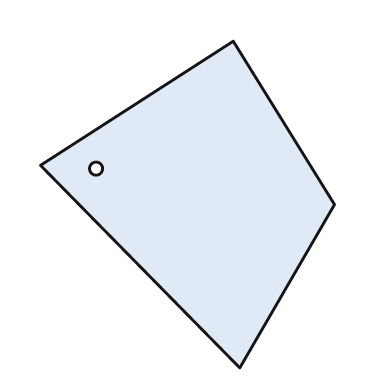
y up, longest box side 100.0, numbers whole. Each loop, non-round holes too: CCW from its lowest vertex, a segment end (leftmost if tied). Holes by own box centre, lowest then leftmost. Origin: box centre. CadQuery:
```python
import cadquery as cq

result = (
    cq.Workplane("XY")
    .moveTo(16.0, -50.0)
    .lineTo(45.0, 0.0)
    .lineTo(14.0, 50.0)
    .lineTo(-45.0, 12.0)
    .close()
    .moveTo(-28.0, 11.0)
    .circle(2.0)
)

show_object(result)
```